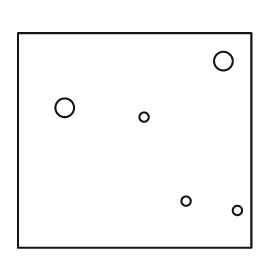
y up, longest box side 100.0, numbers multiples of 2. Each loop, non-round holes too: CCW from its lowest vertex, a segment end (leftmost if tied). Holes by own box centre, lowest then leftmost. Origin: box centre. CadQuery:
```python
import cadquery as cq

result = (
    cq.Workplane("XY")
    .moveTo(-50.0, -46.0)
    .lineTo(50.0, -46.0)
    .lineTo(50.0, 46.0)
    .lineTo(-50.0, 46.0)
    .close()
    .moveTo(44.0, -30.0)
    .circle(2.0)
    .moveTo(22.0, -26.0)
    .circle(2.0)
    .moveTo(4.0, 10.0)
    .circle(2.0)
    .moveTo(-30.0, 14.0)
    .circle(4.0)
    .moveTo(38.0, 34.0)
    .circle(4.0)
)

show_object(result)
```